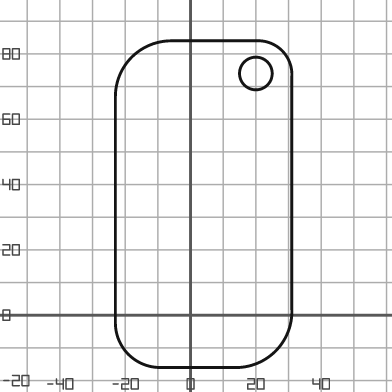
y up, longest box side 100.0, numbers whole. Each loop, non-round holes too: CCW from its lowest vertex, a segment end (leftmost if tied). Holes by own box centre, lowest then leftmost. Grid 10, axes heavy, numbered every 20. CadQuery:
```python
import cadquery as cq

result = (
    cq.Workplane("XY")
    .moveTo(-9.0, -16.0)
    .lineTo(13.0, -16.0)
    .threePointArc((26.0, -11.0), (31.0, 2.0))
    .lineTo(31.0, 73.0)
    .threePointArc((28.0, 81.0), (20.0, 84.0))
    .lineTo(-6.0, 84.0)
    .threePointArc((-18.0, 79.0), (-23.0, 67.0))
    .lineTo(-23.0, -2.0)
    .threePointArc((-19.0, -12.0), (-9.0, -16.0))
    .close()
    .moveTo(20.0, 74.0)
    .circle(5.0)
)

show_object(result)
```